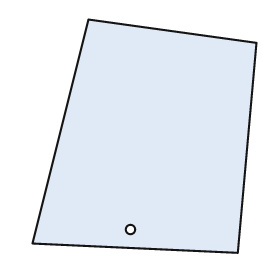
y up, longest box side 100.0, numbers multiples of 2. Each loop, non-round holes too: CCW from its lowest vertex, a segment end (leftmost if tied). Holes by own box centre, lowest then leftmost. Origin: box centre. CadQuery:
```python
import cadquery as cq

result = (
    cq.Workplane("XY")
    .moveTo(40.0, -50.0)
    .lineTo(48.0, 40.0)
    .lineTo(-24.0, 50.0)
    .lineTo(-48.0, -46.0)
    .close()
    .moveTo(-6.0, -40.0)
    .circle(2.0)
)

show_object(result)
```